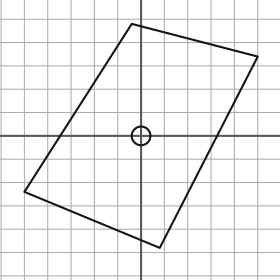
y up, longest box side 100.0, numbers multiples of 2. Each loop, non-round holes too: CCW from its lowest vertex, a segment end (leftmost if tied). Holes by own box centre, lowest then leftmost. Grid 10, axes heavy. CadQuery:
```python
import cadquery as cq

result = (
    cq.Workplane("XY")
    .moveTo(8.0, -48.0)
    .lineTo(50.0, 34.0)
    .lineTo(-4.0, 48.0)
    .lineTo(-50.0, -24.0)
    .close()
    .moveTo(0.0, 0.0)
    .circle(4.0)
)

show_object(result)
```